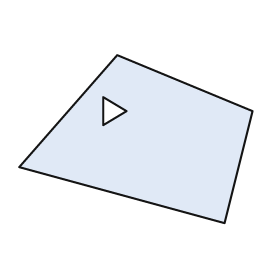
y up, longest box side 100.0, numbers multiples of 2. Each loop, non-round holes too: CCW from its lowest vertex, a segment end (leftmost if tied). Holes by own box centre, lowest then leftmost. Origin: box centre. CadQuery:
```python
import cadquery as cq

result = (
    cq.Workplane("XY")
    .moveTo(38.0, -36.0)
    .lineTo(50.0, 12.0)
    .lineTo(-8.0, 36.0)
    .lineTo(-50.0, -12.0)
    .close()
    .moveTo(-14.0, 6.0)
    .lineTo(-4.0, 12.0)
    .lineTo(-14.0, 18.0)
    .close()
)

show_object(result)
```